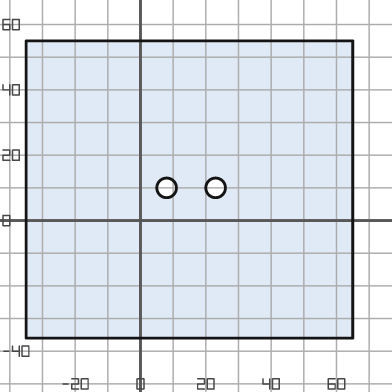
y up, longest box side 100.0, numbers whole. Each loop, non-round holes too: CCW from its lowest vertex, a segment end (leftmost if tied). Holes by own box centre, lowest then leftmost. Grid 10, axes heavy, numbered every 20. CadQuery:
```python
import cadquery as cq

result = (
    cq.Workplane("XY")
    .moveTo(-35.0, -36.0)
    .lineTo(65.0, -36.0)
    .lineTo(65.0, 55.0)
    .lineTo(-35.0, 55.0)
    .close()
    .moveTo(8.0, 10.0)
    .circle(3.0)
    .moveTo(23.0, 10.0)
    .circle(3.0)
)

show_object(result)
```